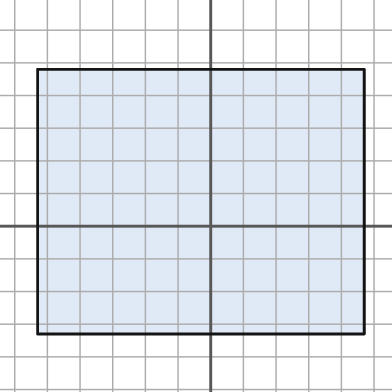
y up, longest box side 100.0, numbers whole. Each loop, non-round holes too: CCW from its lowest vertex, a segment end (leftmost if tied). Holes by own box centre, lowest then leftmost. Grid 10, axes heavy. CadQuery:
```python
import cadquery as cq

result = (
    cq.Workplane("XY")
    .moveTo(-53.0, -33.0)
    .lineTo(47.0, -33.0)
    .lineTo(47.0, 48.0)
    .lineTo(-53.0, 48.0)
    .close()
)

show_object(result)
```